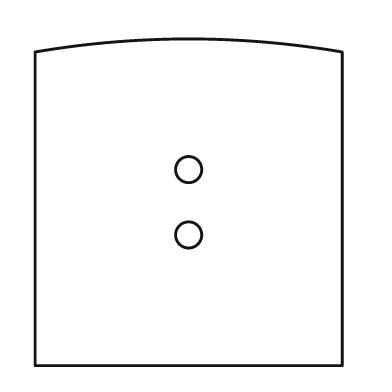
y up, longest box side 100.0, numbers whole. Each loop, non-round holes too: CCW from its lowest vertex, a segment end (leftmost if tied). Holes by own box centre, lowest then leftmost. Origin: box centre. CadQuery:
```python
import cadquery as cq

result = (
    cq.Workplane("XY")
    .moveTo(-47.0, -50.0)
    .lineTo(47.0, -50.0)
    .lineTo(47.0, 46.0)
    .threePointArc((0.0, 50.0), (-47.0, 46.0))
    .close()
    .moveTo(0.0, -10.0)
    .circle(4.0)
    .moveTo(0.0, 10.0)
    .circle(4.0)
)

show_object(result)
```